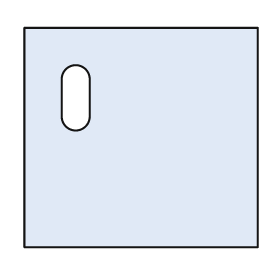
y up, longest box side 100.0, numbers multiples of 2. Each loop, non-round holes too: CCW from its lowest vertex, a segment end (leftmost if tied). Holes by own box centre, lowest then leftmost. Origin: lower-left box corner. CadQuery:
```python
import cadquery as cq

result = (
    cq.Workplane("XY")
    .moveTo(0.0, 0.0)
    .lineTo(100.0, 0.0)
    .lineTo(100.0, 94.0)
    .lineTo(0.0, 94.0)
    .close()
    .moveTo(16.0, 56.0)
    .threePointArc((22.0, 50.0), (28.0, 56.0))
    .lineTo(28.0, 72.0)
    .threePointArc((22.0, 78.0), (16.0, 72.0))
    .close()
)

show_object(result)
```